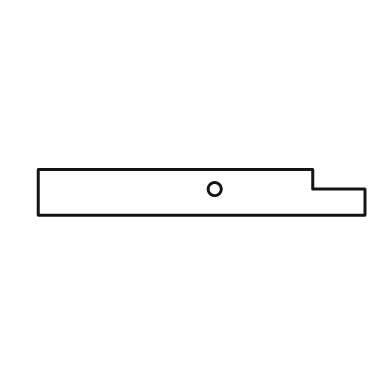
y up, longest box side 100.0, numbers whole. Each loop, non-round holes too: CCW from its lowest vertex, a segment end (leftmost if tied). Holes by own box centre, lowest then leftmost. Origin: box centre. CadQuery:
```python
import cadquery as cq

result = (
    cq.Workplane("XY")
    .moveTo(-50.0, -7.0)
    .lineTo(50.0, -7.0)
    .lineTo(50.0, 1.0)
    .lineTo(34.0, 1.0)
    .lineTo(34.0, 7.0)
    .lineTo(-50.0, 7.0)
    .close()
    .moveTo(4.0, 1.0)
    .circle(2.0)
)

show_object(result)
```